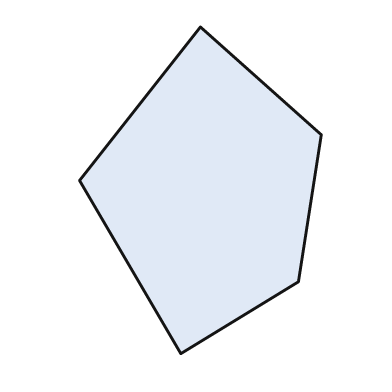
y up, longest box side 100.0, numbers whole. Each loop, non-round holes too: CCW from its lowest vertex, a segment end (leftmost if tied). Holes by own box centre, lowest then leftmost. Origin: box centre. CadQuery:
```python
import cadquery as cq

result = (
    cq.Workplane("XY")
    .moveTo(-6.0, -50.0)
    .lineTo(30.0, -28.0)
    .lineTo(37.0, 17.0)
    .lineTo(0.0, 50.0)
    .lineTo(-37.0, 3.0)
    .close()
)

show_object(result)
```